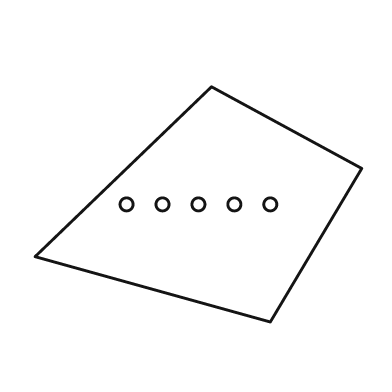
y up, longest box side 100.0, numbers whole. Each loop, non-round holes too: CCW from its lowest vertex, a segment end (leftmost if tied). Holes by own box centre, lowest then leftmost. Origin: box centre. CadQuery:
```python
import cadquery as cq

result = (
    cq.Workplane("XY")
    .moveTo(22.0, -36.0)
    .lineTo(50.0, 11.0)
    .lineTo(4.0, 36.0)
    .lineTo(-50.0, -16.0)
    .close()
    .moveTo(-22.0, 0.0)
    .circle(2.0)
    .moveTo(-11.0, 0.0)
    .circle(2.0)
    .moveTo(0.0, 0.0)
    .circle(2.0)
    .moveTo(11.0, 0.0)
    .circle(2.0)
    .moveTo(22.0, 0.0)
    .circle(2.0)
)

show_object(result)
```